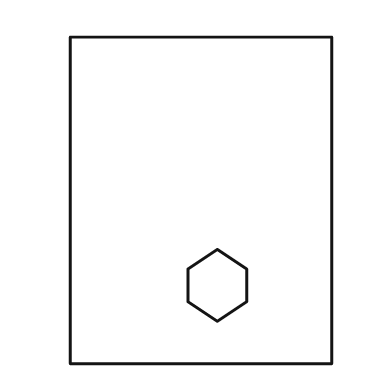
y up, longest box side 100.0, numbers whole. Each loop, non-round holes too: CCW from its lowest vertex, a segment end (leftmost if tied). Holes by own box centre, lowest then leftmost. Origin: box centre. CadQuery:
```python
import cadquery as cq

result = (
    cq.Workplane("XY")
    .moveTo(-40.0, -50.0)
    .lineTo(40.0, -50.0)
    .lineTo(40.0, 50.0)
    .lineTo(-40.0, 50.0)
    .close()
    .moveTo(5.0, -37.0)
    .lineTo(14.0, -31.0)
    .lineTo(14.0, -21.0)
    .lineTo(5.0, -15.0)
    .lineTo(-4.0, -21.0)
    .lineTo(-4.0, -31.0)
    .close()
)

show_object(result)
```